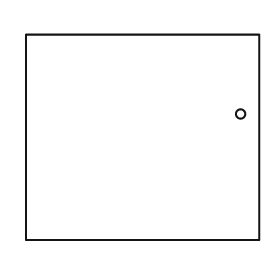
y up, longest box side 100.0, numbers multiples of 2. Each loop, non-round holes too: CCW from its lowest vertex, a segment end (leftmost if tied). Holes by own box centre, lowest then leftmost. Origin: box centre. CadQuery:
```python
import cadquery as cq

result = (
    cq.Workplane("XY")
    .moveTo(-50.0, -44.0)
    .lineTo(50.0, -44.0)
    .lineTo(50.0, 44.0)
    .lineTo(-50.0, 44.0)
    .close()
    .moveTo(42.0, 10.0)
    .circle(2.0)
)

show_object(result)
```